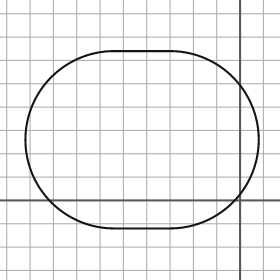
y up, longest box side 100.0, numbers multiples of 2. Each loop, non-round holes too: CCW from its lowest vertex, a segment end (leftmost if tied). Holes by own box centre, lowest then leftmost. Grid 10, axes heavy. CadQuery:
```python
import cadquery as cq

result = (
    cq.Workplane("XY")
    .moveTo(-54.0, -12.0)
    .lineTo(-30.0, -12.0)
    .threePointArc((8.0, 26.0), (-30.0, 64.0))
    .lineTo(-54.0, 64.0)
    .threePointArc((-92.0, 26.0), (-54.0, -12.0))
    .close()
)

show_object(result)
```